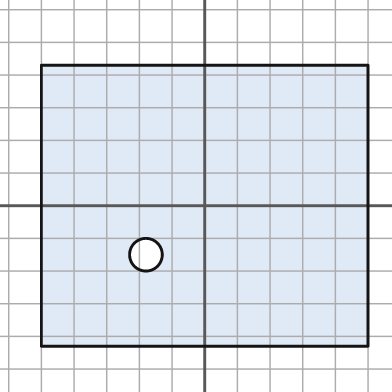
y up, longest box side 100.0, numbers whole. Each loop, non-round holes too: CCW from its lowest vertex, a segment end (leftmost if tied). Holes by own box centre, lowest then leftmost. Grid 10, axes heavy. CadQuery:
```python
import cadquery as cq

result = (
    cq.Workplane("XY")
    .moveTo(-50.0, -43.0)
    .lineTo(50.0, -43.0)
    .lineTo(50.0, 43.0)
    .lineTo(-50.0, 43.0)
    .close()
    .moveTo(-18.0, -15.0)
    .circle(5.0)
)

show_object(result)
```